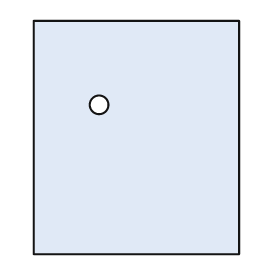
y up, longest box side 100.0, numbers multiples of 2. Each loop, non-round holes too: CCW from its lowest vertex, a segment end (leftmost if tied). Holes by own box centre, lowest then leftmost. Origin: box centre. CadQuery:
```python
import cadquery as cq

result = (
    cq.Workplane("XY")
    .moveTo(-44.0, -50.0)
    .lineTo(44.0, -50.0)
    .lineTo(44.0, 50.0)
    .lineTo(-44.0, 50.0)
    .close()
    .moveTo(-16.0, 14.0)
    .circle(4.0)
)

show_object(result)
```